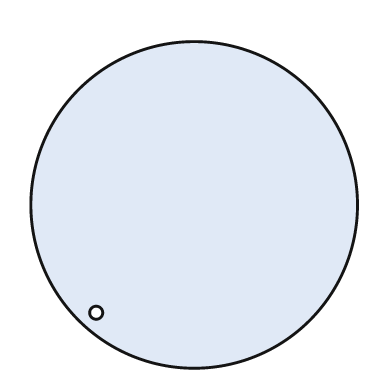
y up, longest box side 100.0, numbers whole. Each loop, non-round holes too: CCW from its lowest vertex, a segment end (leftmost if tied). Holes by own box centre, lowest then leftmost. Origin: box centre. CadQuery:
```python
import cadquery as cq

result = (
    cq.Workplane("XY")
    .moveTo(0.0, 0.0)
    .circle(50.0)
    .moveTo(-30.0, -33.0)
    .circle(2.0)
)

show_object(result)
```